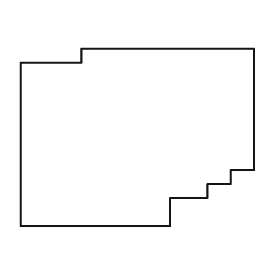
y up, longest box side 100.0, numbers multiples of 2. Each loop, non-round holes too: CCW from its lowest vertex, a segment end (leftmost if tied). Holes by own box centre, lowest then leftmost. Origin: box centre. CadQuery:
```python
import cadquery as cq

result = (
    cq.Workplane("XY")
    .moveTo(-50.0, -38.0)
    .lineTo(14.0, -38.0)
    .lineTo(14.0, -26.0)
    .lineTo(30.0, -26.0)
    .lineTo(30.0, -20.0)
    .lineTo(40.0, -20.0)
    .lineTo(40.0, -14.0)
    .lineTo(50.0, -14.0)
    .lineTo(50.0, 38.0)
    .lineTo(-24.0, 38.0)
    .lineTo(-24.0, 32.0)
    .lineTo(-50.0, 32.0)
    .close()
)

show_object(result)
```